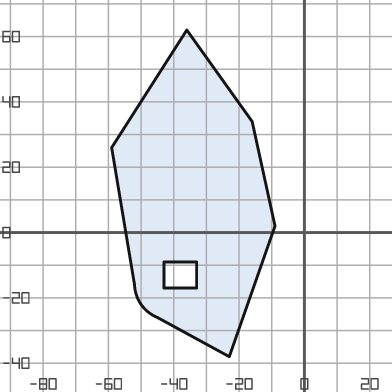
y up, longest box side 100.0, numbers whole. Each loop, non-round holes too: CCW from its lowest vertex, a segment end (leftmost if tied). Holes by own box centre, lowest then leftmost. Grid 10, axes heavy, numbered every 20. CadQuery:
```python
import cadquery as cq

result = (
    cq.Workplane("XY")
    .moveTo(-23.0, -38.0)
    .lineTo(-9.0, 2.0)
    .lineTo(-16.0, 34.0)
    .lineTo(-36.0, 62.0)
    .lineTo(-59.0, 26.0)
    .lineTo(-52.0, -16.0)
    .threePointArc((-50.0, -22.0), (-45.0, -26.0))
    .close()
    .moveTo(-43.0, -17.0)
    .lineTo(-33.0, -17.0)
    .lineTo(-33.0, -9.0)
    .lineTo(-43.0, -9.0)
    .close()
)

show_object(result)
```